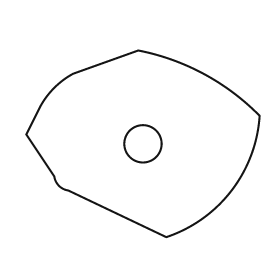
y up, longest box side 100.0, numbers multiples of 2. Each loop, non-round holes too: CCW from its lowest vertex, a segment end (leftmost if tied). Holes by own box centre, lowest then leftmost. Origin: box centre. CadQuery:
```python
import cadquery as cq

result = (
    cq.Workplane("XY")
    .moveTo(10.0, -40.0)
    .threePointArc((38.0, -20.0), (50.0, 12.0))
    .threePointArc((26.0, 30.0), (-2.0, 40.0))
    .lineTo(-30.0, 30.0)
    .threePointArc((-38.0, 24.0), (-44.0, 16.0))
    .lineTo(-50.0, 4.0)
    .lineTo(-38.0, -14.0)
    .threePointArc((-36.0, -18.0), (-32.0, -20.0))
    .close()
    .moveTo(0.0, 0.0)
    .circle(8.0)
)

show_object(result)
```